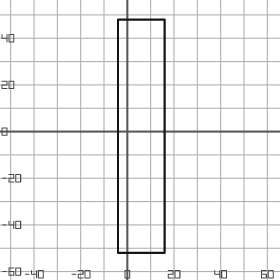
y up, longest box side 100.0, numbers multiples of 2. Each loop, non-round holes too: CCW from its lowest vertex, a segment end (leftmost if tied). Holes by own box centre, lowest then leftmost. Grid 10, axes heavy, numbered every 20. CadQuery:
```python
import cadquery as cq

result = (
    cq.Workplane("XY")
    .moveTo(-4.0, -52.0)
    .lineTo(16.0, -52.0)
    .lineTo(16.0, 48.0)
    .lineTo(-4.0, 48.0)
    .close()
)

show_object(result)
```